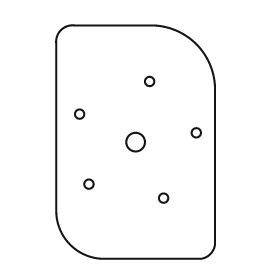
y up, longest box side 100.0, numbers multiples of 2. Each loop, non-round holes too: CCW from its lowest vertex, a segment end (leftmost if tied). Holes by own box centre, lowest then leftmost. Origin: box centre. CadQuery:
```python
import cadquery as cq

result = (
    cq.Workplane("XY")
    .moveTo(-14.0, -50.0)
    .lineTo(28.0, -50.0)
    .threePointArc((32.0, -48.0), (34.0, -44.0))
    .lineTo(34.0, 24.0)
    .threePointArc((26.0, 42.0), (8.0, 50.0))
    .lineTo(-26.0, 50.0)
    .threePointArc((-32.0, 48.0), (-34.0, 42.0))
    .lineTo(-34.0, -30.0)
    .threePointArc((-28.0, -44.0), (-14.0, -50.0))
    .close()
    .moveTo(12.0, -24.0)
    .circle(2.0)
    .moveTo(-20.0, -18.0)
    .circle(2.0)
    .moveTo(0.0, 0.0)
    .circle(4.0)
    .moveTo(26.0, 4.0)
    .circle(2.0)
    .moveTo(-24.0, 12.0)
    .circle(2.0)
    .moveTo(6.0, 26.0)
    .circle(2.0)
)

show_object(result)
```